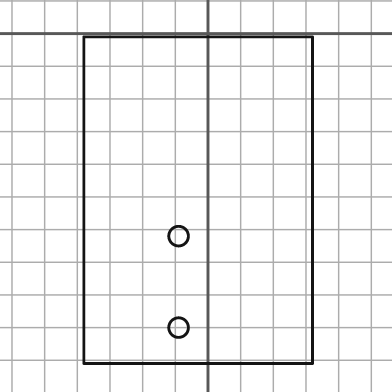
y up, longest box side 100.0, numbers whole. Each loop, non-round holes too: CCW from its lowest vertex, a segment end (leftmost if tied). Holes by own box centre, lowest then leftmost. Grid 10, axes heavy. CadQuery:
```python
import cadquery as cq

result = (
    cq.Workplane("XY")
    .moveTo(-38.0, -101.0)
    .lineTo(32.0, -101.0)
    .lineTo(32.0, -1.0)
    .lineTo(-38.0, -1.0)
    .close()
    .moveTo(-9.0, -90.0)
    .circle(3.0)
    .moveTo(-9.0, -62.0)
    .circle(3.0)
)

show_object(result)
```